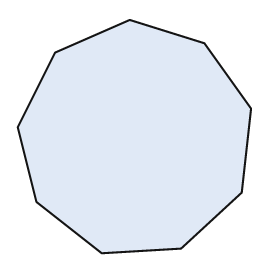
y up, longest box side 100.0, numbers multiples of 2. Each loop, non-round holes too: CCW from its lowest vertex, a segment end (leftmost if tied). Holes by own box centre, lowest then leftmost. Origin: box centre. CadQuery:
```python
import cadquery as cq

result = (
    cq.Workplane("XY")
    .moveTo(-14.0, -50.0)
    .lineTo(20.0, -48.0)
    .lineTo(46.0, -24.0)
    .lineTo(50.0, 12.0)
    .lineTo(30.0, 40.0)
    .lineTo(-2.0, 50.0)
    .lineTo(-34.0, 36.0)
    .lineTo(-50.0, 4.0)
    .lineTo(-42.0, -28.0)
    .close()
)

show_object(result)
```